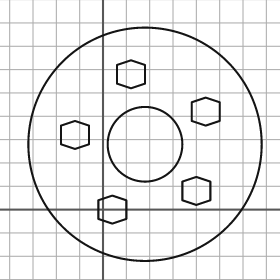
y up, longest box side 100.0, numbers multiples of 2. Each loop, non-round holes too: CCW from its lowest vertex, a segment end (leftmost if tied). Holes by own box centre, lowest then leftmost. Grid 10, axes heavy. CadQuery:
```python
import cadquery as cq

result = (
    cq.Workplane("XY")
    .moveTo(18.0, 28.0)
    .circle(50.0)
    .moveTo(4.0, -6.0)
    .lineTo(10.0, -4.0)
    .lineTo(10.0, 4.0)
    .lineTo(4.0, 6.0)
    .lineTo(-2.0, 4.0)
    .lineTo(-2.0, -4.0)
    .close()
    .moveTo(40.0, 2.0)
    .lineTo(46.0, 4.0)
    .lineTo(46.0, 12.0)
    .lineTo(40.0, 14.0)
    .lineTo(34.0, 12.0)
    .lineTo(34.0, 4.0)
    .close()
    .moveTo(18.0, 28.0)
    .circle(16.0)
    .moveTo(-12.0, 26.0)
    .lineTo(-6.0, 28.0)
    .lineTo(-6.0, 36.0)
    .lineTo(-12.0, 38.0)
    .lineTo(-18.0, 36.0)
    .lineTo(-18.0, 28.0)
    .close()
    .moveTo(44.0, 36.0)
    .lineTo(50.0, 38.0)
    .lineTo(50.0, 46.0)
    .lineTo(44.0, 48.0)
    .lineTo(38.0, 46.0)
    .lineTo(38.0, 38.0)
    .close()
    .moveTo(12.0, 52.0)
    .lineTo(18.0, 54.0)
    .lineTo(18.0, 62.0)
    .lineTo(12.0, 64.0)
    .lineTo(6.0, 62.0)
    .lineTo(6.0, 54.0)
    .close()
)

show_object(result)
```